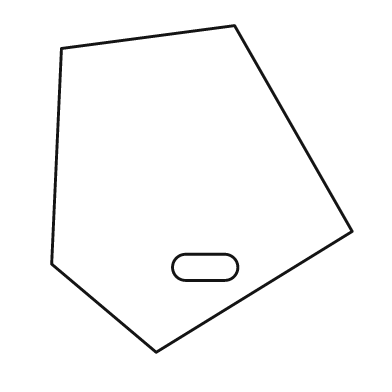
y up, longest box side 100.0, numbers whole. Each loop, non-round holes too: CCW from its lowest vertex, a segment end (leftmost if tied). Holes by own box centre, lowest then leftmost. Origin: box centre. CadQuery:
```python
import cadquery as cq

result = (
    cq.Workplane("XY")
    .moveTo(-14.0, -50.0)
    .lineTo(46.0, -13.0)
    .lineTo(10.0, 50.0)
    .lineTo(-43.0, 43.0)
    .lineTo(-46.0, -23.0)
    .close()
    .moveTo(-5.0, -28.0)
    .lineTo(7.0, -28.0)
    .threePointArc((11.0, -24.0), (7.0, -20.0))
    .lineTo(-5.0, -20.0)
    .threePointArc((-9.0, -24.0), (-5.0, -28.0))
    .close()
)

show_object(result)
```